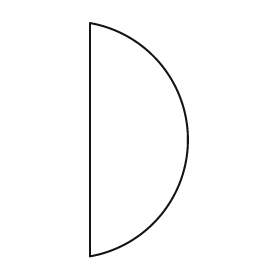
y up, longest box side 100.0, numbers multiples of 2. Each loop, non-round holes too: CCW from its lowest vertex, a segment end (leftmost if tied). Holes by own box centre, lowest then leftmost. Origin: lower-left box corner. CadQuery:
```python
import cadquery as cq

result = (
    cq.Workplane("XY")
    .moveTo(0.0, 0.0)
    .threePointArc((42.0, 50.0), (0.0, 100.0))
    .close()
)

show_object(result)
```